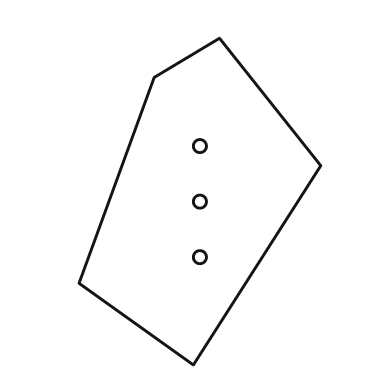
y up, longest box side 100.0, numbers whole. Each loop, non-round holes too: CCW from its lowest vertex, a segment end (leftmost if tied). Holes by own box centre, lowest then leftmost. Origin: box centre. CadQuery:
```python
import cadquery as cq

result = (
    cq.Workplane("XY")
    .moveTo(-2.0, -50.0)
    .lineTo(37.0, 11.0)
    .lineTo(6.0, 50.0)
    .lineTo(-14.0, 38.0)
    .lineTo(-37.0, -25.0)
    .close()
    .moveTo(0.0, -17.0)
    .circle(2.0)
    .moveTo(0.0, 0.0)
    .circle(2.0)
    .moveTo(0.0, 17.0)
    .circle(2.0)
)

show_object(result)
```